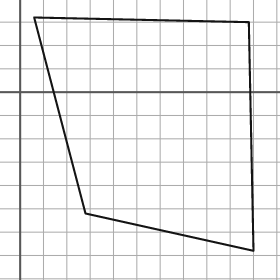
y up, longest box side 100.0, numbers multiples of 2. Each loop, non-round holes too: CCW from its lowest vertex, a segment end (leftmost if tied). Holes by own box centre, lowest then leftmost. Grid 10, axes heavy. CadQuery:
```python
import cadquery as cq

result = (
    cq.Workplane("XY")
    .moveTo(100.0, -68.0)
    .lineTo(98.0, 30.0)
    .lineTo(6.0, 32.0)
    .lineTo(28.0, -52.0)
    .close()
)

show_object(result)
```